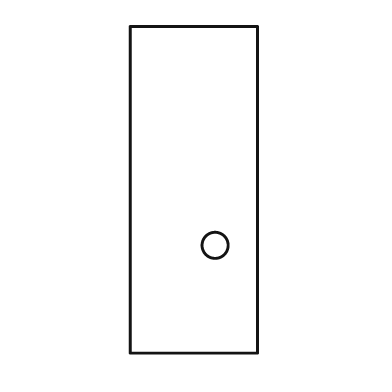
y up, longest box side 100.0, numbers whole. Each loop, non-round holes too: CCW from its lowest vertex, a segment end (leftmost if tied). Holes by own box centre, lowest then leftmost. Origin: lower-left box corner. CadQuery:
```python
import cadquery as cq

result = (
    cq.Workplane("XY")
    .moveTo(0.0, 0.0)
    .lineTo(39.0, 0.0)
    .lineTo(39.0, 100.0)
    .lineTo(0.0, 100.0)
    .close()
    .moveTo(26.0, 33.0)
    .circle(4.0)
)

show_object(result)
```